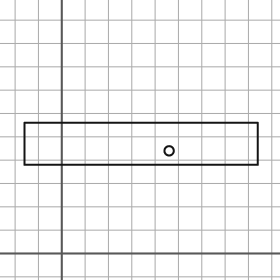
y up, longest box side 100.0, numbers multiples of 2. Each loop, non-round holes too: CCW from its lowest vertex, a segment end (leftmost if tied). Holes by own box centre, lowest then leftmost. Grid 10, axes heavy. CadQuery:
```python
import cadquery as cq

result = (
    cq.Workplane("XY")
    .moveTo(-16.0, 38.0)
    .lineTo(84.0, 38.0)
    .lineTo(84.0, 56.0)
    .lineTo(-16.0, 56.0)
    .close()
    .moveTo(46.0, 44.0)
    .circle(2.0)
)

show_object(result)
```